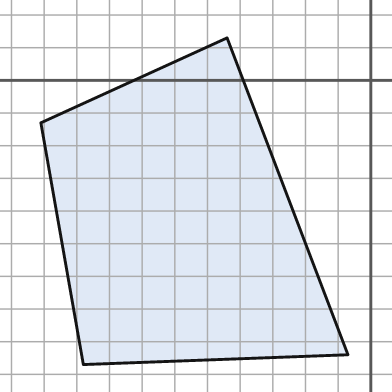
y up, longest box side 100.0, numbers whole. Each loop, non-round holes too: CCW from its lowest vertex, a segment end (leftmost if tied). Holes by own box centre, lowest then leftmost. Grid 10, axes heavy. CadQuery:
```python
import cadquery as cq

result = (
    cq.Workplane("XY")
    .moveTo(-88.0, -87.0)
    .lineTo(-7.0, -84.0)
    .lineTo(-44.0, 13.0)
    .lineTo(-101.0, -13.0)
    .close()
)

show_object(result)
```